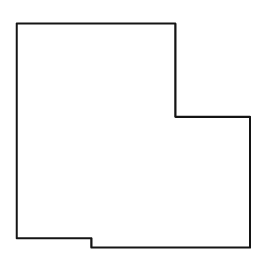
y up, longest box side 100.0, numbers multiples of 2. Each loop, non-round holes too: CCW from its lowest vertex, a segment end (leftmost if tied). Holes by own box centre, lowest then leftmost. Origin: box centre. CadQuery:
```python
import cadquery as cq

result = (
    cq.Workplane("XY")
    .moveTo(-18.0, -48.0)
    .lineTo(50.0, -48.0)
    .lineTo(50.0, 8.0)
    .lineTo(18.0, 8.0)
    .lineTo(18.0, 48.0)
    .lineTo(-50.0, 48.0)
    .lineTo(-50.0, -44.0)
    .lineTo(-18.0, -44.0)
    .close()
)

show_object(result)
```